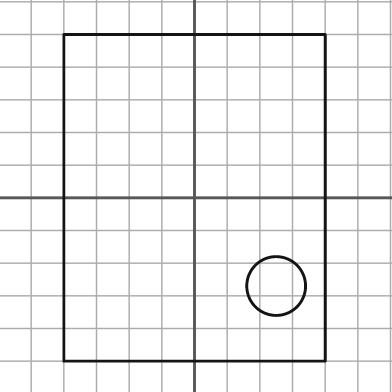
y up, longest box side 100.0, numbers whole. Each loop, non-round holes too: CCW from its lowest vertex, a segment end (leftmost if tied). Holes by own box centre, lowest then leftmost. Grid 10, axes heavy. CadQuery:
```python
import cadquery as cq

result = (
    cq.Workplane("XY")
    .moveTo(-40.0, -50.0)
    .lineTo(40.0, -50.0)
    .lineTo(40.0, 50.0)
    .lineTo(-40.0, 50.0)
    .close()
    .moveTo(25.0, -27.0)
    .circle(9.0)
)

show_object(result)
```